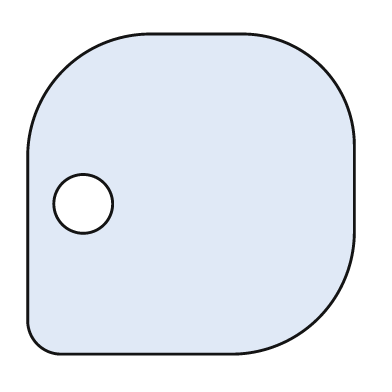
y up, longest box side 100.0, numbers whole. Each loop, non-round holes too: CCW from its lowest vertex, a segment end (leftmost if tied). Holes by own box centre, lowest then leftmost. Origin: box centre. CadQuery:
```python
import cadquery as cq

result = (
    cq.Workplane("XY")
    .moveTo(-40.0, -49.0)
    .lineTo(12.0, -49.0)
    .threePointArc((39.0, -38.0), (50.0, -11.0))
    .lineTo(50.0, 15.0)
    .threePointArc((40.0, 39.0), (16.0, 49.0))
    .lineTo(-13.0, 49.0)
    .threePointArc((-39.0, 38.0), (-50.0, 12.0))
    .lineTo(-50.0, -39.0)
    .threePointArc((-47.0, -46.0), (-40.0, -49.0))
    .close()
    .moveTo(-33.0, -3.0)
    .circle(9.0)
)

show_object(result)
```